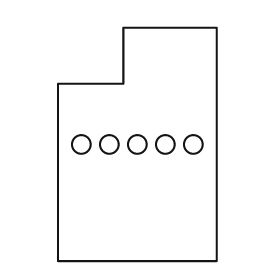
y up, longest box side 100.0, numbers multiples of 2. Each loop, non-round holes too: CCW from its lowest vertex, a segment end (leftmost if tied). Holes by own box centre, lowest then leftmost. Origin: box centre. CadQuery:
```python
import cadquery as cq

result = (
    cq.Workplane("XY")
    .moveTo(-34.0, -50.0)
    .lineTo(34.0, -50.0)
    .lineTo(34.0, 50.0)
    .lineTo(-6.0, 50.0)
    .lineTo(-6.0, 26.0)
    .lineTo(-34.0, 26.0)
    .close()
    .moveTo(-24.0, 0.0)
    .circle(4.0)
    .moveTo(-12.0, 0.0)
    .circle(4.0)
    .moveTo(0.0, 0.0)
    .circle(4.0)
    .moveTo(12.0, 0.0)
    .circle(4.0)
    .moveTo(24.0, 0.0)
    .circle(4.0)
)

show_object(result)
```